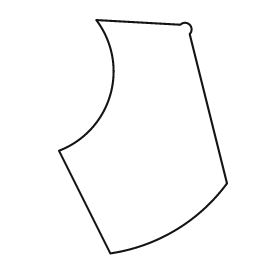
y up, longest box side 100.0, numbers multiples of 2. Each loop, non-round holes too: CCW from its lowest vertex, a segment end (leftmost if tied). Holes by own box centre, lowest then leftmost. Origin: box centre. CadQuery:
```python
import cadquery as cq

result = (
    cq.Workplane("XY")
    .moveTo(-14.0, -50.0)
    .threePointArc((14.0, -40.0), (36.0, -20.0))
    .lineTo(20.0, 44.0)
    .threePointArc((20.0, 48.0), (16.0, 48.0))
    .lineTo(-20.0, 50.0)
    .threePointArc((-14.0, 18.0), (-36.0, -6.0))
    .close()
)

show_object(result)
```